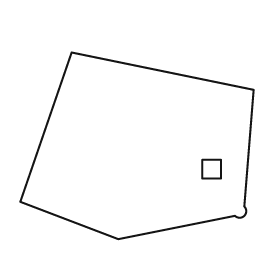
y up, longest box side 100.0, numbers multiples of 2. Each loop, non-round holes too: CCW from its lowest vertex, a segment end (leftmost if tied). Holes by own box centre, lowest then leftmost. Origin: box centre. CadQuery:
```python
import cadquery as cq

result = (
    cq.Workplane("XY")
    .moveTo(-8.0, -40.0)
    .lineTo(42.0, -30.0)
    .threePointArc((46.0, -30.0), (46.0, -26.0))
    .lineTo(50.0, 24.0)
    .lineTo(-28.0, 40.0)
    .lineTo(-50.0, -24.0)
    .close()
    .moveTo(28.0, -14.0)
    .lineTo(36.0, -14.0)
    .lineTo(36.0, -6.0)
    .lineTo(28.0, -6.0)
    .close()
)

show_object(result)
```